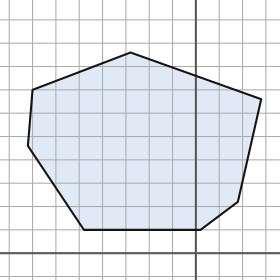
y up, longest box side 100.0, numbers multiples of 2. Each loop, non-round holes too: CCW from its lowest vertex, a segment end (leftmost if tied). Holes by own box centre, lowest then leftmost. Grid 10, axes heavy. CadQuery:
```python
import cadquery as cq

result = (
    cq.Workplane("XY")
    .moveTo(-48.0, 10.0)
    .lineTo(2.0, 10.0)
    .lineTo(18.0, 22.0)
    .lineTo(28.0, 66.0)
    .lineTo(-28.0, 86.0)
    .lineTo(-70.0, 70.0)
    .lineTo(-72.0, 46.0)
    .close()
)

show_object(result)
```